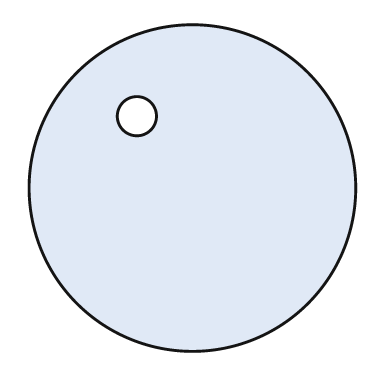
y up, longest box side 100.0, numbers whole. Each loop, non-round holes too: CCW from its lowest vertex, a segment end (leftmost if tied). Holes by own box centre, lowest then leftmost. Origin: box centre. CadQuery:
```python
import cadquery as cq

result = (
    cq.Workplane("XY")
    .moveTo(0.0, 0.0)
    .circle(50.0)
    .moveTo(-17.0, 22.0)
    .circle(6.0)
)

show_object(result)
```